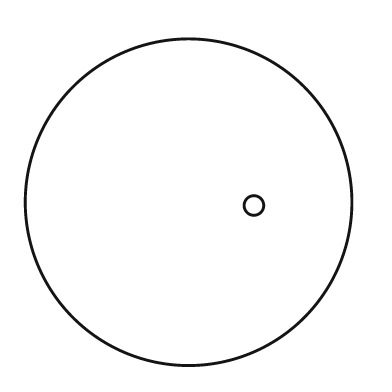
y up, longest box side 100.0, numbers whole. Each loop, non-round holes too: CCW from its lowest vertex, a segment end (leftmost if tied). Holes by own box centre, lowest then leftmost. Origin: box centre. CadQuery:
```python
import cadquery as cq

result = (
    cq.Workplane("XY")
    .moveTo(0.0, 0.0)
    .circle(50.0)
    .moveTo(20.0, -1.0)
    .circle(3.0)
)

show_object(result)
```